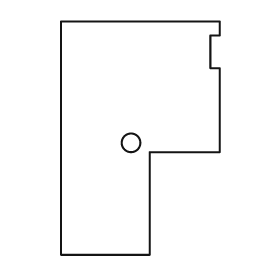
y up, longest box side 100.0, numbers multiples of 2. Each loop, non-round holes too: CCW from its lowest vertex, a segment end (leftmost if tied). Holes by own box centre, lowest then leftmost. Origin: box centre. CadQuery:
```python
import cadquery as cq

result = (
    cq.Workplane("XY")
    .moveTo(-34.0, -50.0)
    .lineTo(4.0, -50.0)
    .lineTo(4.0, -6.0)
    .lineTo(34.0, -6.0)
    .lineTo(34.0, 30.0)
    .lineTo(30.0, 30.0)
    .lineTo(30.0, 44.0)
    .lineTo(34.0, 44.0)
    .lineTo(34.0, 50.0)
    .lineTo(-34.0, 50.0)
    .close()
    .moveTo(-4.0, -2.0)
    .circle(4.0)
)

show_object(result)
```